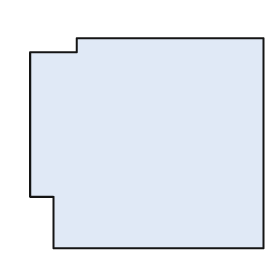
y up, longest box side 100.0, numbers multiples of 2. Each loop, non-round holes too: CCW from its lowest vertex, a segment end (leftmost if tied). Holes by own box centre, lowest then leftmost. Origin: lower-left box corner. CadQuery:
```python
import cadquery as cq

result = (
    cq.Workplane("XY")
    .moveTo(10.0, 0.0)
    .lineTo(100.0, 0.0)
    .lineTo(100.0, 90.0)
    .lineTo(20.0, 90.0)
    .lineTo(20.0, 84.0)
    .lineTo(0.0, 84.0)
    .lineTo(0.0, 22.0)
    .lineTo(10.0, 22.0)
    .close()
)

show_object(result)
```